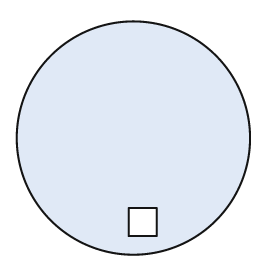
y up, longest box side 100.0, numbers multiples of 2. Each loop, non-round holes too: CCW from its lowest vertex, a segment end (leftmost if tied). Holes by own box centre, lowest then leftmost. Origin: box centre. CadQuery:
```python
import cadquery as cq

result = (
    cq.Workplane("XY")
    .moveTo(0.0, 0.0)
    .circle(50.0)
    .moveTo(-2.0, -42.0)
    .lineTo(10.0, -42.0)
    .lineTo(10.0, -30.0)
    .lineTo(-2.0, -30.0)
    .close()
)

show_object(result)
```